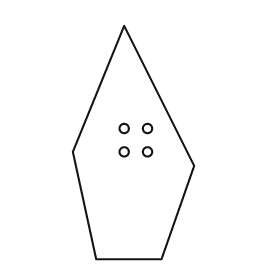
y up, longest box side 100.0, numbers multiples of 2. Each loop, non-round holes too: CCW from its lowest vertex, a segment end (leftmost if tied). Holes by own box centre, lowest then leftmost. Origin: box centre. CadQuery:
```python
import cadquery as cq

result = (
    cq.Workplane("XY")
    .moveTo(-16.0, -50.0)
    .lineTo(12.0, -50.0)
    .lineTo(26.0, -10.0)
    .lineTo(-4.0, 50.0)
    .lineTo(-26.0, -4.0)
    .close()
    .moveTo(-4.0, -4.0)
    .circle(2.0)
    .moveTo(6.0, -4.0)
    .circle(2.0)
    .moveTo(-4.0, 6.0)
    .circle(2.0)
    .moveTo(6.0, 6.0)
    .circle(2.0)
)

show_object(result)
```